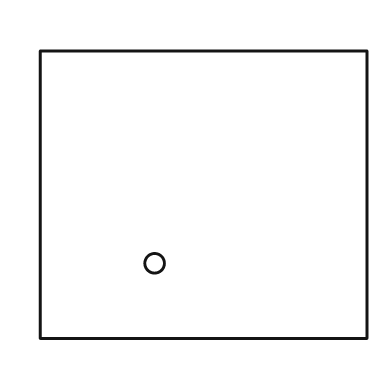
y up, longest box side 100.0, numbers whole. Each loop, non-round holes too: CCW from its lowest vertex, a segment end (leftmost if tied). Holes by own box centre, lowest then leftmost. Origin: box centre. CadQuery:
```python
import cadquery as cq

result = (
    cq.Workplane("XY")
    .moveTo(-50.0, -44.0)
    .lineTo(50.0, -44.0)
    .lineTo(50.0, 44.0)
    .lineTo(-50.0, 44.0)
    .close()
    .moveTo(-15.0, -21.0)
    .circle(3.0)
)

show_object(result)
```